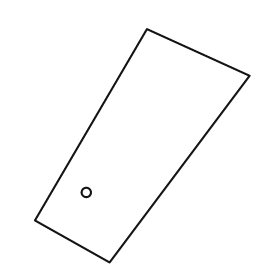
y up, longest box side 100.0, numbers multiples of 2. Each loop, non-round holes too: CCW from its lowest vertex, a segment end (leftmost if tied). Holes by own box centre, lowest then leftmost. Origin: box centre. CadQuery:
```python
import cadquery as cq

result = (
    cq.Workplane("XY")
    .moveTo(-14.0, -50.0)
    .lineTo(46.0, 30.0)
    .lineTo(2.0, 50.0)
    .lineTo(-46.0, -32.0)
    .close()
    .moveTo(-24.0, -20.0)
    .circle(2.0)
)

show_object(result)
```